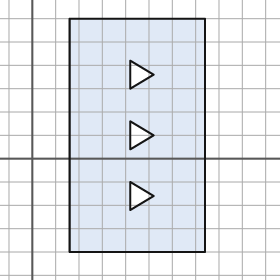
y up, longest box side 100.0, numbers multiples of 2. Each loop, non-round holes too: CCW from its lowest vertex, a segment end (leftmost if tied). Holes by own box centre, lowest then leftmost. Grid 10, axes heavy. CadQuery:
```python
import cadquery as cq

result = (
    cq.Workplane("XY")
    .moveTo(16.0, -40.0)
    .lineTo(74.0, -40.0)
    .lineTo(74.0, 60.0)
    .lineTo(16.0, 60.0)
    .close()
    .moveTo(42.0, -22.0)
    .lineTo(52.0, -16.0)
    .lineTo(42.0, -10.0)
    .close()
    .moveTo(42.0, 4.0)
    .lineTo(52.0, 10.0)
    .lineTo(42.0, 16.0)
    .close()
    .moveTo(42.0, 30.0)
    .lineTo(52.0, 36.0)
    .lineTo(42.0, 42.0)
    .close()
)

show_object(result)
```